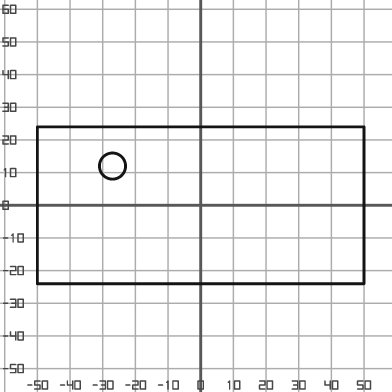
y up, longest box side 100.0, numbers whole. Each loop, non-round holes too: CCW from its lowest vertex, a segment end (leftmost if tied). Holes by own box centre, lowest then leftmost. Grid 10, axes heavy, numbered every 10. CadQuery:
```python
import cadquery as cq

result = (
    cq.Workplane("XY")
    .moveTo(-50.0, -24.0)
    .lineTo(50.0, -24.0)
    .lineTo(50.0, 24.0)
    .lineTo(-50.0, 24.0)
    .close()
    .moveTo(-27.0, 12.0)
    .circle(4.0)
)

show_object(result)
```